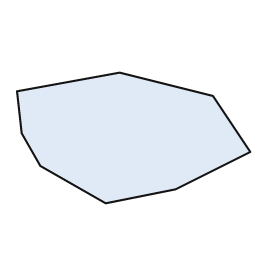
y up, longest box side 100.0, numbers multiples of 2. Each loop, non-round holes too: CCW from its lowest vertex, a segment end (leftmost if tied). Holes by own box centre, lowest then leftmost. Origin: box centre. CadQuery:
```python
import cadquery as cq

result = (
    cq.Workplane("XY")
    .moveTo(-12.0, -28.0)
    .lineTo(18.0, -22.0)
    .lineTo(50.0, -6.0)
    .lineTo(34.0, 18.0)
    .lineTo(-6.0, 28.0)
    .lineTo(-50.0, 20.0)
    .lineTo(-48.0, 2.0)
    .lineTo(-40.0, -12.0)
    .close()
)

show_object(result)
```